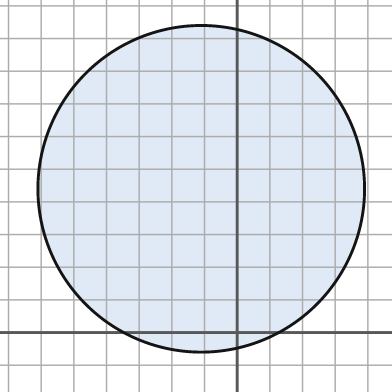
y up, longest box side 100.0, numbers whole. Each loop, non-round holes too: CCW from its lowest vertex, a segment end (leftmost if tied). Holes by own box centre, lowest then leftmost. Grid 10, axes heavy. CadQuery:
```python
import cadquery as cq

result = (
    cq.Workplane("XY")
    .moveTo(-11.0, 44.0)
    .circle(50.0)
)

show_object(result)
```